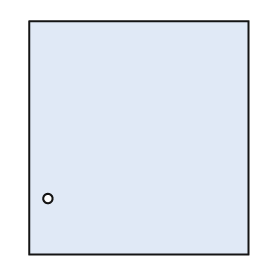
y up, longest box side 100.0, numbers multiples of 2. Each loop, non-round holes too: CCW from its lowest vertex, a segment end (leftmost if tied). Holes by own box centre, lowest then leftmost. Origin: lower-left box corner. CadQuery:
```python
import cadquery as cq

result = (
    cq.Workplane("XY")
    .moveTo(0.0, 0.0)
    .lineTo(94.0, 0.0)
    .lineTo(94.0, 100.0)
    .lineTo(0.0, 100.0)
    .close()
    .moveTo(8.0, 24.0)
    .circle(2.0)
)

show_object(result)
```